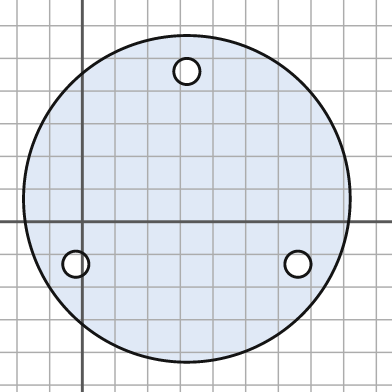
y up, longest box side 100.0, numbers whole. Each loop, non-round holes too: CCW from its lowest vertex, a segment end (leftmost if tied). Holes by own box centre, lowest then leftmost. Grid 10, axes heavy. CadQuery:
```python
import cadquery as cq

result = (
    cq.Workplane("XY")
    .moveTo(32.0, 7.0)
    .circle(50.0)
    .moveTo(-2.0, -13.0)
    .circle(4.0)
    .moveTo(66.0, -13.0)
    .circle(4.0)
    .moveTo(32.0, 46.0)
    .circle(4.0)
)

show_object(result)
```